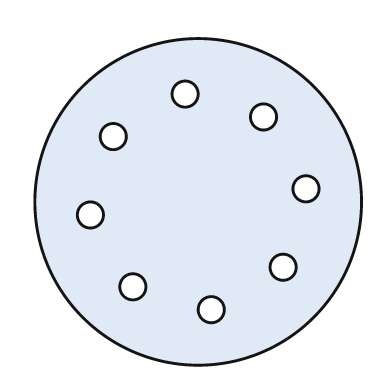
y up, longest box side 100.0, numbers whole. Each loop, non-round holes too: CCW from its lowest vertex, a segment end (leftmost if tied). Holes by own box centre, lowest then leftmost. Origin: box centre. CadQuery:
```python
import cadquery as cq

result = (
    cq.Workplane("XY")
    .moveTo(0.0, 0.0)
    .circle(50.0)
    .moveTo(4.0, -33.0)
    .circle(4.0)
    .moveTo(-20.0, -26.0)
    .circle(4.0)
    .moveTo(26.0, -20.0)
    .circle(4.0)
    .moveTo(-33.0, -4.0)
    .circle(4.0)
    .moveTo(33.0, 4.0)
    .circle(4.0)
    .moveTo(-26.0, 20.0)
    .circle(4.0)
    .moveTo(20.0, 26.0)
    .circle(4.0)
    .moveTo(-4.0, 33.0)
    .circle(4.0)
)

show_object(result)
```